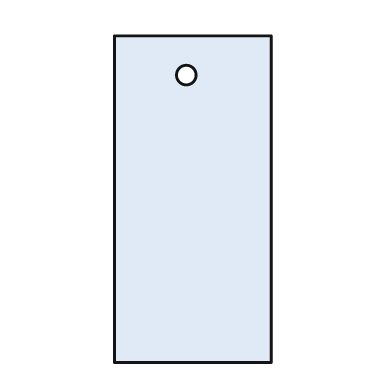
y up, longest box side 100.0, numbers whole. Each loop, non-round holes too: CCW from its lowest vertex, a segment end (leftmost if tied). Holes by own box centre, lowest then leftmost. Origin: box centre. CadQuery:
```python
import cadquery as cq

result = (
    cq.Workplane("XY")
    .moveTo(-24.0, -50.0)
    .lineTo(24.0, -50.0)
    .lineTo(24.0, 50.0)
    .lineTo(-24.0, 50.0)
    .close()
    .moveTo(-2.0, 38.0)
    .circle(3.0)
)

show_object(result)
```